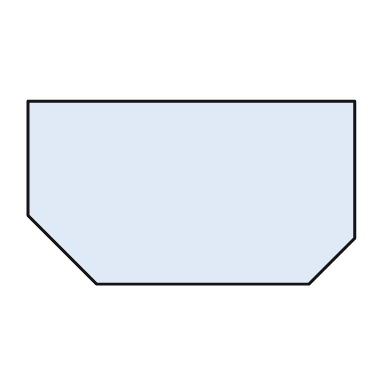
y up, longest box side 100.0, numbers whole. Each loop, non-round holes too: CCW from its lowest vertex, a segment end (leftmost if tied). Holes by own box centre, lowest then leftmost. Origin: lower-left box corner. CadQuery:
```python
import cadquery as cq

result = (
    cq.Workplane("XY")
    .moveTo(21.0, 0.0)
    .lineTo(86.0, 0.0)
    .lineTo(100.0, 14.0)
    .lineTo(100.0, 56.0)
    .lineTo(0.0, 56.0)
    .lineTo(0.0, 21.0)
    .close()
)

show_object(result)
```